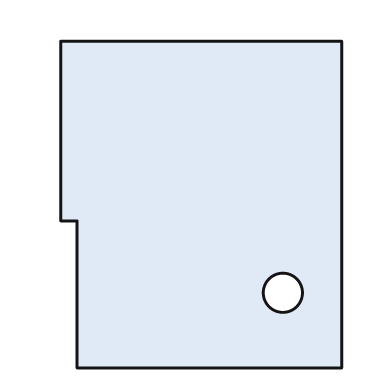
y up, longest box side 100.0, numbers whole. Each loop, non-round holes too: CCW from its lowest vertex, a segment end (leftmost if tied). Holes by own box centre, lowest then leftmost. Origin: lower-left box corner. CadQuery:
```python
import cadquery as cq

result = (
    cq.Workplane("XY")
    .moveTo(5.0, 0.0)
    .lineTo(86.0, 0.0)
    .lineTo(86.0, 100.0)
    .lineTo(0.0, 100.0)
    .lineTo(0.0, 45.0)
    .lineTo(5.0, 45.0)
    .close()
    .moveTo(68.0, 23.0)
    .circle(6.0)
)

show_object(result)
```